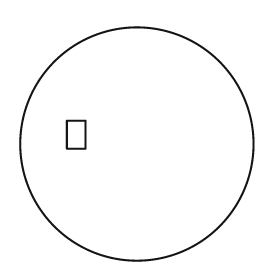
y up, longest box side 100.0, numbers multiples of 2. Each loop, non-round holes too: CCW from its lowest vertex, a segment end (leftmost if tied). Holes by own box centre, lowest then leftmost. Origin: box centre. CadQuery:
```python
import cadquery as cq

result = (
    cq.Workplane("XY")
    .moveTo(0.0, 0.0)
    .circle(50.0)
    .moveTo(-30.0, -2.0)
    .lineTo(-22.0, -2.0)
    .lineTo(-22.0, 10.0)
    .lineTo(-30.0, 10.0)
    .close()
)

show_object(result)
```